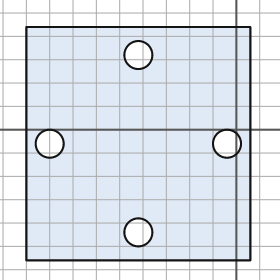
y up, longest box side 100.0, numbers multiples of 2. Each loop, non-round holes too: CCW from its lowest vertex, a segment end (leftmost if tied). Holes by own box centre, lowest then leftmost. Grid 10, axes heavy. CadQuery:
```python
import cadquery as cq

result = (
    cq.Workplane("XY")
    .moveTo(-90.0, -56.0)
    .lineTo(6.0, -56.0)
    .lineTo(6.0, 44.0)
    .lineTo(-90.0, 44.0)
    .close()
    .moveTo(-42.0, -44.0)
    .circle(6.0)
    .moveTo(-80.0, -6.0)
    .circle(6.0)
    .moveTo(-4.0, -6.0)
    .circle(6.0)
    .moveTo(-42.0, 32.0)
    .circle(6.0)
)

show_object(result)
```